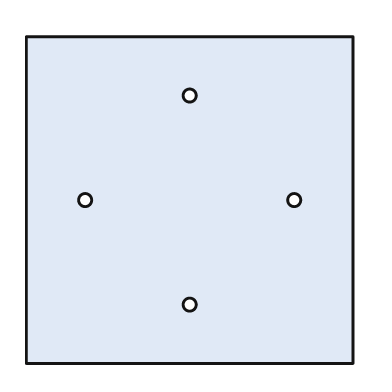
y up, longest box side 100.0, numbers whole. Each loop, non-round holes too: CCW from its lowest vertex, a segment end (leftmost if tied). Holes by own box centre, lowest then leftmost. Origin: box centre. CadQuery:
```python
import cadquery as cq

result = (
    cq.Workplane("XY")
    .moveTo(-50.0, -50.0)
    .lineTo(50.0, -50.0)
    .lineTo(50.0, 50.0)
    .lineTo(-50.0, 50.0)
    .close()
    .moveTo(0.0, -32.0)
    .circle(2.0)
    .moveTo(-32.0, 0.0)
    .circle(2.0)
    .moveTo(32.0, 0.0)
    .circle(2.0)
    .moveTo(0.0, 32.0)
    .circle(2.0)
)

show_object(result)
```